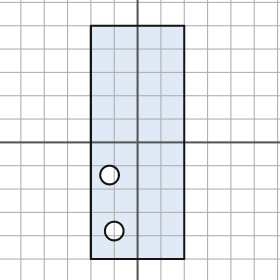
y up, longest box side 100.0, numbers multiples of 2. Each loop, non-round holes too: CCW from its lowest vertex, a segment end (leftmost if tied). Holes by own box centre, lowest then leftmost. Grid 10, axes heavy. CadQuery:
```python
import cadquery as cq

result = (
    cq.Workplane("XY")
    .moveTo(-20.0, -50.0)
    .lineTo(20.0, -50.0)
    .lineTo(20.0, 50.0)
    .lineTo(-20.0, 50.0)
    .close()
    .moveTo(-10.0, -38.0)
    .circle(4.0)
    .moveTo(-12.0, -14.0)
    .circle(4.0)
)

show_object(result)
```